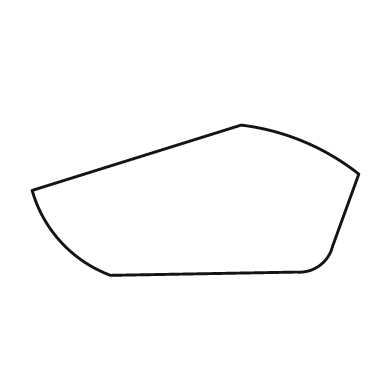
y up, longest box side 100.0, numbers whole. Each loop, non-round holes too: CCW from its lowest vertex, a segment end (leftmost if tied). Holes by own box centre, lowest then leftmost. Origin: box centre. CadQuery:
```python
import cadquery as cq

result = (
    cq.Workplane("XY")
    .moveTo(-26.0, -23.0)
    .lineTo(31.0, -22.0)
    .threePointArc((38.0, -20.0), (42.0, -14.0))
    .lineTo(50.0, 8.0)
    .threePointArc((33.0, 18.0), (14.0, 23.0))
    .lineTo(-50.0, 3.0)
    .threePointArc((-41.0, -13.0), (-26.0, -23.0))
    .close()
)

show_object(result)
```